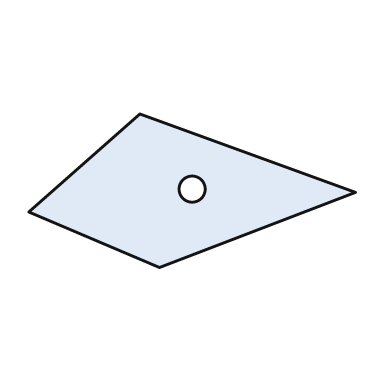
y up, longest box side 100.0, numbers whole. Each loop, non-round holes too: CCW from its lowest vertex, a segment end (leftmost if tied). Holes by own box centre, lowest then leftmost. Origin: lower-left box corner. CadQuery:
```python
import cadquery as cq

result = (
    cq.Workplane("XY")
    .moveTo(40.0, 0.0)
    .lineTo(100.0, 23.0)
    .lineTo(34.0, 47.0)
    .lineTo(0.0, 17.0)
    .close()
    .moveTo(50.0, 24.0)
    .circle(4.0)
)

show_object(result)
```